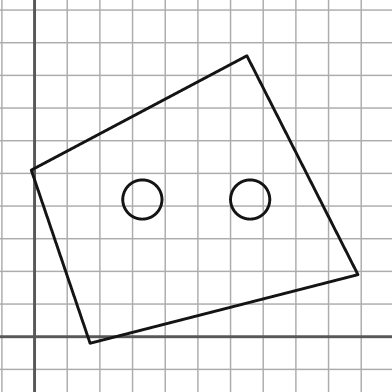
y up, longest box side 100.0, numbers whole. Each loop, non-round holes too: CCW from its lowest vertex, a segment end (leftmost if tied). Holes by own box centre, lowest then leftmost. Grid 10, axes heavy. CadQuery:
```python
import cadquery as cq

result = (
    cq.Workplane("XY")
    .moveTo(17.0, -2.0)
    .lineTo(99.0, 19.0)
    .lineTo(65.0, 86.0)
    .lineTo(-1.0, 51.0)
    .close()
    .moveTo(33.0, 42.0)
    .circle(6.0)
    .moveTo(66.0, 42.0)
    .circle(6.0)
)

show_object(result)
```